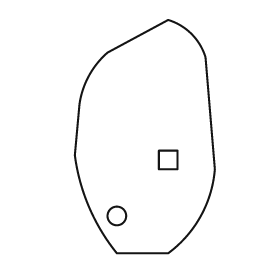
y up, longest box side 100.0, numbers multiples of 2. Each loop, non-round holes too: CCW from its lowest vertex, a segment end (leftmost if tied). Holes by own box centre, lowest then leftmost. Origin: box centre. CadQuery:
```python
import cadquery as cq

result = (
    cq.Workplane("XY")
    .moveTo(-12.0, -50.0)
    .lineTo(10.0, -50.0)
    .threePointArc((24.0, -34.0), (30.0, -14.0))
    .lineTo(26.0, 34.0)
    .threePointArc((20.0, 44.0), (10.0, 50.0))
    .lineTo(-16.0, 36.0)
    .threePointArc((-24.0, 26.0), (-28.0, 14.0))
    .lineTo(-30.0, -8.0)
    .threePointArc((-24.0, -30.0), (-12.0, -50.0))
    .close()
    .moveTo(-12.0, -34.0)
    .circle(4.0)
    .moveTo(6.0, -14.0)
    .lineTo(14.0, -14.0)
    .lineTo(14.0, -6.0)
    .lineTo(6.0, -6.0)
    .close()
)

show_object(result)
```